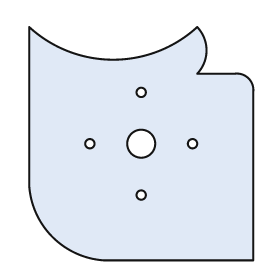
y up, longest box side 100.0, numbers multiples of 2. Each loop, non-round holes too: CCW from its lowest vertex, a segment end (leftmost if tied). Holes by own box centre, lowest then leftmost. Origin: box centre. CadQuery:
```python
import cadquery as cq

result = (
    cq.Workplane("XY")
    .moveTo(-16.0, -50.0)
    .lineTo(48.0, -50.0)
    .lineTo(48.0, 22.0)
    .threePointArc((46.0, 28.0), (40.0, 30.0))
    .lineTo(24.0, 30.0)
    .threePointArc((28.0, 40.0), (24.0, 50.0))
    .threePointArc((-12.0, 36.0), (-48.0, 50.0))
    .lineTo(-48.0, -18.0)
    .threePointArc((-38.0, -40.0), (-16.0, -50.0))
    .close()
    .moveTo(0.0, -22.0)
    .circle(2.0)
    .moveTo(-22.0, 0.0)
    .circle(2.0)
    .moveTo(0.0, 0.0)
    .circle(6.0)
    .moveTo(22.0, 0.0)
    .circle(2.0)
    .moveTo(0.0, 22.0)
    .circle(2.0)
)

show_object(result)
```